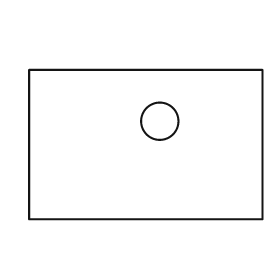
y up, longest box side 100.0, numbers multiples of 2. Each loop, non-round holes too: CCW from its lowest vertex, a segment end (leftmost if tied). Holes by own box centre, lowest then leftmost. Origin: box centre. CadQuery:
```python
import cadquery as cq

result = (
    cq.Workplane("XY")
    .moveTo(-50.0, -32.0)
    .lineTo(50.0, -32.0)
    .lineTo(50.0, 32.0)
    .lineTo(-50.0, 32.0)
    .close()
    .moveTo(6.0, 10.0)
    .circle(8.0)
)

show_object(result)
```